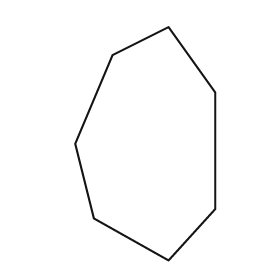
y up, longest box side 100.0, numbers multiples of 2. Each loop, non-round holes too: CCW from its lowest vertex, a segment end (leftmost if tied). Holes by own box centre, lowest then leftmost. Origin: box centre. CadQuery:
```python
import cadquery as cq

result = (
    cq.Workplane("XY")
    .moveTo(10.0, -50.0)
    .lineTo(30.0, -28.0)
    .lineTo(30.0, 22.0)
    .lineTo(10.0, 50.0)
    .lineTo(-14.0, 38.0)
    .lineTo(-30.0, 0.0)
    .lineTo(-22.0, -32.0)
    .close()
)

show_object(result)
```